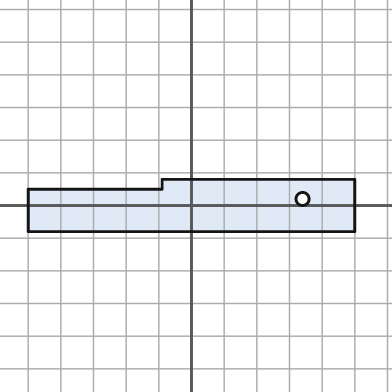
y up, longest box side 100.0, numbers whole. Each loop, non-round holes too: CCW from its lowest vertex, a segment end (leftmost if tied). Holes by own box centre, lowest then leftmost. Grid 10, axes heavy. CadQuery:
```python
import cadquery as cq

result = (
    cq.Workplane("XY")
    .moveTo(-50.0, -8.0)
    .lineTo(50.0, -8.0)
    .lineTo(50.0, 8.0)
    .lineTo(-9.0, 8.0)
    .lineTo(-9.0, 5.0)
    .lineTo(-50.0, 5.0)
    .close()
    .moveTo(34.0, 2.0)
    .circle(2.0)
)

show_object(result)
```